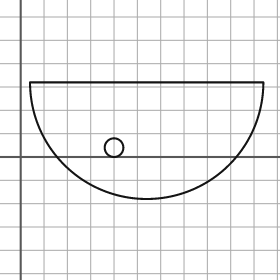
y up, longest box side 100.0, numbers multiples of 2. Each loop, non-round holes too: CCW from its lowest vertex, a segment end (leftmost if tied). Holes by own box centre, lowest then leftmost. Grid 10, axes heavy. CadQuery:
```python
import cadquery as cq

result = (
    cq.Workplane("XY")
    .moveTo(4.0, 32.0)
    .threePointArc((54.0, -18.0), (104.0, 32.0))
    .close()
    .moveTo(40.0, 4.0)
    .circle(4.0)
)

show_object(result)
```